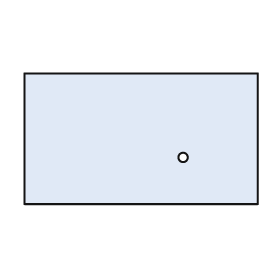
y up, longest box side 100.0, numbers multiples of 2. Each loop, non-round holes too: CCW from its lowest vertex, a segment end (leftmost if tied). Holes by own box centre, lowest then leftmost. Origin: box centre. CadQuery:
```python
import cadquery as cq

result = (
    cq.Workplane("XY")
    .moveTo(-50.0, -28.0)
    .lineTo(50.0, -28.0)
    .lineTo(50.0, 28.0)
    .lineTo(-50.0, 28.0)
    .close()
    .moveTo(18.0, -8.0)
    .circle(2.0)
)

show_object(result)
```